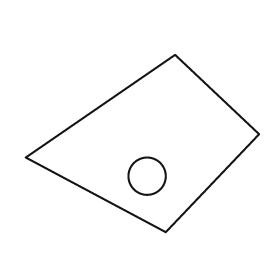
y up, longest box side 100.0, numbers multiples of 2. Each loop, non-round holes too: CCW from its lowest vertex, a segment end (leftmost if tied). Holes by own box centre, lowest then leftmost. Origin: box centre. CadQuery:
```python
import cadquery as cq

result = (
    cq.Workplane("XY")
    .moveTo(10.0, -38.0)
    .lineTo(50.0, 4.0)
    .lineTo(14.0, 38.0)
    .lineTo(-50.0, -6.0)
    .close()
    .moveTo(2.0, -14.0)
    .circle(8.0)
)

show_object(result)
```